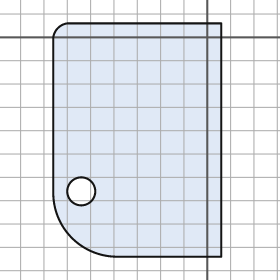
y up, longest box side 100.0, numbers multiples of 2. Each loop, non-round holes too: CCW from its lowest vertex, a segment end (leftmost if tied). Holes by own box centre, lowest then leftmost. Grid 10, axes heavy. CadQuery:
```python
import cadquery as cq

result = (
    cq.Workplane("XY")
    .moveTo(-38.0, -94.0)
    .lineTo(6.0, -94.0)
    .lineTo(6.0, 6.0)
    .lineTo(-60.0, 6.0)
    .threePointArc((-64.0, 4.0), (-66.0, 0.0))
    .lineTo(-66.0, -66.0)
    .threePointArc((-58.0, -86.0), (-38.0, -94.0))
    .close()
    .moveTo(-54.0, -66.0)
    .circle(6.0)
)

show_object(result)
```